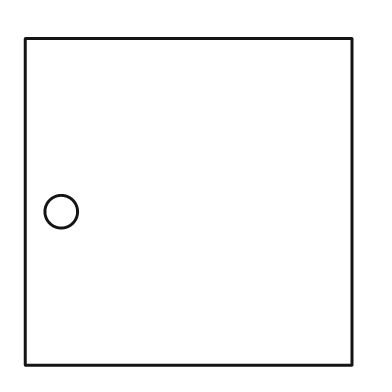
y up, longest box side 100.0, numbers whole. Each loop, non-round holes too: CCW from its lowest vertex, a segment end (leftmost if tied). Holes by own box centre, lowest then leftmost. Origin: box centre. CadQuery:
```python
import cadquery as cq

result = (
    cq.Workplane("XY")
    .moveTo(-50.0, -50.0)
    .lineTo(50.0, -50.0)
    .lineTo(50.0, 50.0)
    .lineTo(-50.0, 50.0)
    .close()
    .moveTo(-39.0, -3.0)
    .circle(5.0)
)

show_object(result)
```